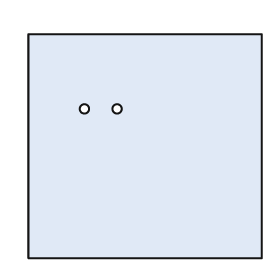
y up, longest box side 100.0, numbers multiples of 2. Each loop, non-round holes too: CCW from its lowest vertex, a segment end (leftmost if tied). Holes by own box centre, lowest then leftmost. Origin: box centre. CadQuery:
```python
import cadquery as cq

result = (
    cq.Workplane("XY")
    .moveTo(-50.0, -48.0)
    .lineTo(50.0, -48.0)
    .lineTo(50.0, 48.0)
    .lineTo(-50.0, 48.0)
    .close()
    .moveTo(-26.0, 16.0)
    .circle(2.0)
    .moveTo(-12.0, 16.0)
    .circle(2.0)
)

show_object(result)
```